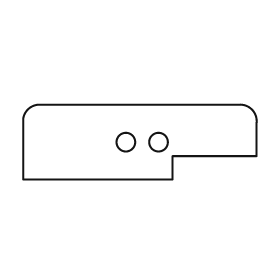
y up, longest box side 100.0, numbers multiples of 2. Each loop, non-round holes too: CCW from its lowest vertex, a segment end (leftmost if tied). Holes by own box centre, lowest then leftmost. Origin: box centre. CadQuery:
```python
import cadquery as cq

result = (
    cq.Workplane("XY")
    .moveTo(-50.0, -16.0)
    .lineTo(14.0, -16.0)
    .lineTo(14.0, -6.0)
    .lineTo(50.0, -6.0)
    .lineTo(50.0, 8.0)
    .threePointArc((48.0, 14.0), (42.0, 16.0))
    .lineTo(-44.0, 16.0)
    .threePointArc((-48.0, 14.0), (-50.0, 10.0))
    .close()
    .moveTo(-6.0, 0.0)
    .circle(4.0)
    .moveTo(8.0, 0.0)
    .circle(4.0)
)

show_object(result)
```